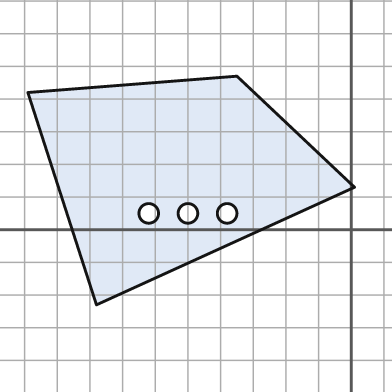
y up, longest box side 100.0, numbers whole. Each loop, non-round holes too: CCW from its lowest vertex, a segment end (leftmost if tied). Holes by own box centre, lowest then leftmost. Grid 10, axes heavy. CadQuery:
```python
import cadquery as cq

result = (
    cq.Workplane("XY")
    .moveTo(-78.0, -23.0)
    .lineTo(1.0, 13.0)
    .lineTo(-35.0, 47.0)
    .lineTo(-99.0, 42.0)
    .close()
    .moveTo(-62.0, 5.0)
    .circle(3.0)
    .moveTo(-50.0, 5.0)
    .circle(3.0)
    .moveTo(-38.0, 5.0)
    .circle(3.0)
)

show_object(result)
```